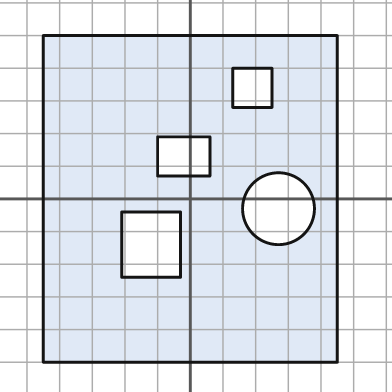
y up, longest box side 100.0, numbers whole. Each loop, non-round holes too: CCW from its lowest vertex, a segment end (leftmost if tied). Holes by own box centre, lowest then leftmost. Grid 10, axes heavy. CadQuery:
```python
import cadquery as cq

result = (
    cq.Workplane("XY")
    .moveTo(-45.0, -50.0)
    .lineTo(45.0, -50.0)
    .lineTo(45.0, 50.0)
    .lineTo(-45.0, 50.0)
    .close()
    .moveTo(-21.0, -24.0)
    .lineTo(-3.0, -24.0)
    .lineTo(-3.0, -4.0)
    .lineTo(-21.0, -4.0)
    .close()
    .moveTo(27.0, -3.0)
    .circle(11.0)
    .moveTo(-10.0, 7.0)
    .lineTo(6.0, 7.0)
    .lineTo(6.0, 19.0)
    .lineTo(-10.0, 19.0)
    .close()
    .moveTo(13.0, 28.0)
    .lineTo(25.0, 28.0)
    .lineTo(25.0, 40.0)
    .lineTo(13.0, 40.0)
    .close()
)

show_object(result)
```